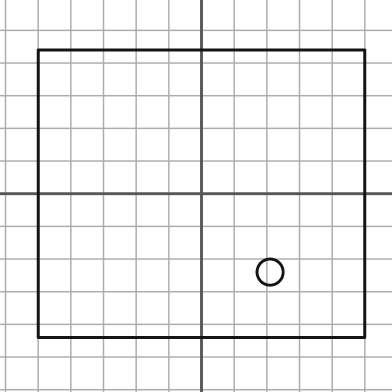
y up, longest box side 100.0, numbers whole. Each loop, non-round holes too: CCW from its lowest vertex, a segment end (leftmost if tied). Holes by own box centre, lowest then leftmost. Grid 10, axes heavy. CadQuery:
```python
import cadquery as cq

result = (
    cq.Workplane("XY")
    .moveTo(-50.0, -44.0)
    .lineTo(50.0, -44.0)
    .lineTo(50.0, 44.0)
    .lineTo(-50.0, 44.0)
    .close()
    .moveTo(21.0, -24.0)
    .circle(4.0)
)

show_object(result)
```